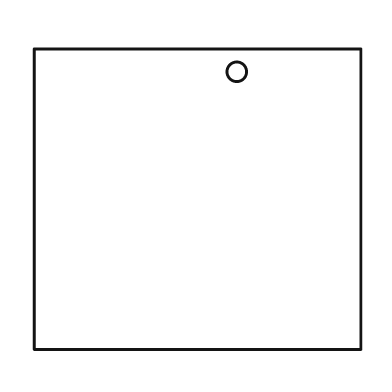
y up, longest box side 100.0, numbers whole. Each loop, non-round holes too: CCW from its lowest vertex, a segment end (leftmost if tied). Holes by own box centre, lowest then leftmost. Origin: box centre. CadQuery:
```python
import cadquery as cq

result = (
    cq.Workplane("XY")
    .moveTo(-50.0, -46.0)
    .lineTo(50.0, -46.0)
    .lineTo(50.0, 46.0)
    .lineTo(-50.0, 46.0)
    .close()
    .moveTo(12.0, 39.0)
    .circle(3.0)
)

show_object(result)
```